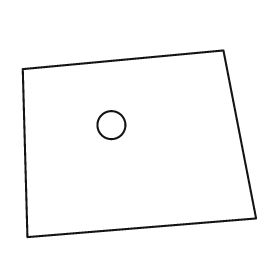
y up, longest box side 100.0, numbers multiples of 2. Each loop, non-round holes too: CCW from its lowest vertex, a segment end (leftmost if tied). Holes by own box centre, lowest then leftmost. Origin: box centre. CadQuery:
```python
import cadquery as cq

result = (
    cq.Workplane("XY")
    .moveTo(-48.0, -40.0)
    .lineTo(50.0, -32.0)
    .lineTo(36.0, 40.0)
    .lineTo(-50.0, 32.0)
    .close()
    .moveTo(-12.0, 8.0)
    .circle(6.0)
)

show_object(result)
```